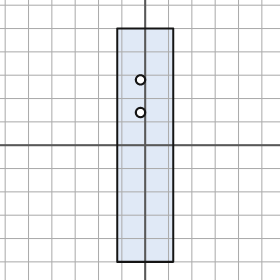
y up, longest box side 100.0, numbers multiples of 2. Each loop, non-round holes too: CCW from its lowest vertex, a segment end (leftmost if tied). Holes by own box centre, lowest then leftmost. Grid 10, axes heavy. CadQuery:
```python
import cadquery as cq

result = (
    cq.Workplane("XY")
    .moveTo(-12.0, -50.0)
    .lineTo(12.0, -50.0)
    .lineTo(12.0, 50.0)
    .lineTo(-12.0, 50.0)
    .close()
    .moveTo(-2.0, 14.0)
    .circle(2.0)
    .moveTo(-2.0, 28.0)
    .circle(2.0)
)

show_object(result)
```